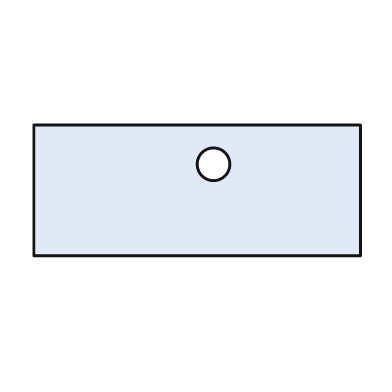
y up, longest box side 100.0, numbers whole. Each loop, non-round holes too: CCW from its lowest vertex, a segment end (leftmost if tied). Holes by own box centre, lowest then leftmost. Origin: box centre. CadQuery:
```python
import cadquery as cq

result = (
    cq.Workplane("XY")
    .moveTo(-50.0, -20.0)
    .lineTo(50.0, -20.0)
    .lineTo(50.0, 20.0)
    .lineTo(-50.0, 20.0)
    .close()
    .moveTo(5.0, 8.0)
    .circle(5.0)
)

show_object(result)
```